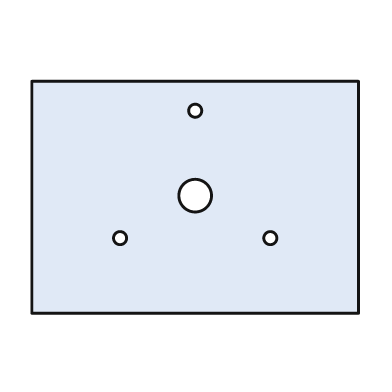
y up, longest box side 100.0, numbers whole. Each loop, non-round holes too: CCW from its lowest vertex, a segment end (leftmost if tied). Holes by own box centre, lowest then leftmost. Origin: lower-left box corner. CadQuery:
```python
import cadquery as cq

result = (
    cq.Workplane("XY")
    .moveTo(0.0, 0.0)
    .lineTo(100.0, 0.0)
    .lineTo(100.0, 71.0)
    .lineTo(0.0, 71.0)
    .close()
    .moveTo(27.0, 23.0)
    .circle(2.0)
    .moveTo(73.0, 23.0)
    .circle(2.0)
    .moveTo(50.0, 36.0)
    .circle(5.0)
    .moveTo(50.0, 62.0)
    .circle(2.0)
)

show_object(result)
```